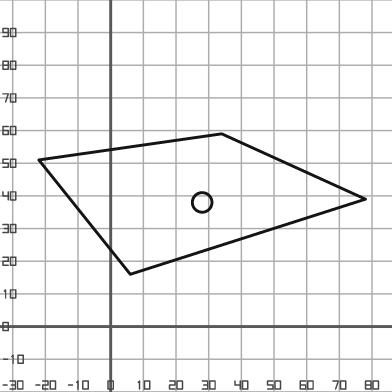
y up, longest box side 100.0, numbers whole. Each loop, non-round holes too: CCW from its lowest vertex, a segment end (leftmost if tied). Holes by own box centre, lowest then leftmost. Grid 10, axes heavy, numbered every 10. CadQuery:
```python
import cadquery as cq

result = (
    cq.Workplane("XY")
    .moveTo(6.0, 16.0)
    .lineTo(78.0, 39.0)
    .lineTo(34.0, 59.0)
    .lineTo(-22.0, 51.0)
    .close()
    .moveTo(28.0, 38.0)
    .circle(3.0)
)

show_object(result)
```